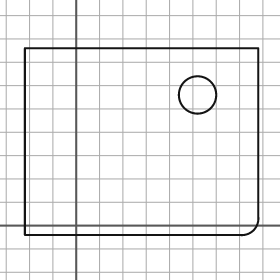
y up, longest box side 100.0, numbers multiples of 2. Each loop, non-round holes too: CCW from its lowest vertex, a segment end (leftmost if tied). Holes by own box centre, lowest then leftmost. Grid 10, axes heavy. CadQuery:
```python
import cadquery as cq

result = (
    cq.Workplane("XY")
    .moveTo(-22.0, -4.0)
    .lineTo(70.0, -4.0)
    .threePointArc((76.0, -2.0), (78.0, 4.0))
    .lineTo(78.0, 76.0)
    .lineTo(-22.0, 76.0)
    .close()
    .moveTo(52.0, 56.0)
    .circle(8.0)
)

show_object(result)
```